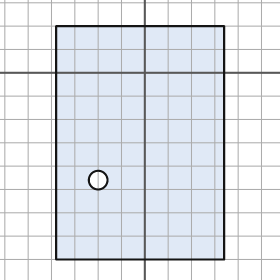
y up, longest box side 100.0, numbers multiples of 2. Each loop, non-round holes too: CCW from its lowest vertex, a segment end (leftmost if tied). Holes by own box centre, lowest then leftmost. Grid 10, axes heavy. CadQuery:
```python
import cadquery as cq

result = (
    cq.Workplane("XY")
    .moveTo(-38.0, -80.0)
    .lineTo(34.0, -80.0)
    .lineTo(34.0, 20.0)
    .lineTo(-38.0, 20.0)
    .close()
    .moveTo(-20.0, -46.0)
    .circle(4.0)
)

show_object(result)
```